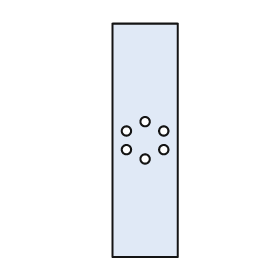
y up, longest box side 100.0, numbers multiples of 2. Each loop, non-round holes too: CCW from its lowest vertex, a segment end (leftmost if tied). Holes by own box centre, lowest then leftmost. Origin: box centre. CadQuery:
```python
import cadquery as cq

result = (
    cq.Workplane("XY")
    .moveTo(-14.0, -50.0)
    .lineTo(14.0, -50.0)
    .lineTo(14.0, 50.0)
    .lineTo(-14.0, 50.0)
    .close()
    .moveTo(0.0, -8.0)
    .circle(2.0)
    .moveTo(-8.0, -4.0)
    .circle(2.0)
    .moveTo(8.0, -4.0)
    .circle(2.0)
    .moveTo(-8.0, 4.0)
    .circle(2.0)
    .moveTo(8.0, 4.0)
    .circle(2.0)
    .moveTo(0.0, 8.0)
    .circle(2.0)
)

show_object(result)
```